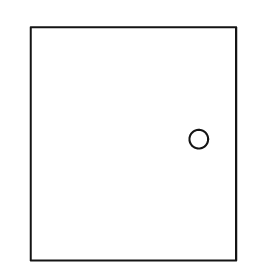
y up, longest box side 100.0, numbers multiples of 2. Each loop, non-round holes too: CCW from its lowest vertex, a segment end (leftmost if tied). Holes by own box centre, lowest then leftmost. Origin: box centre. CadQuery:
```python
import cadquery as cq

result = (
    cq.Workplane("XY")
    .moveTo(-44.0, -50.0)
    .lineTo(44.0, -50.0)
    .lineTo(44.0, 50.0)
    .lineTo(-44.0, 50.0)
    .close()
    .moveTo(28.0, 2.0)
    .circle(4.0)
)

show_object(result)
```